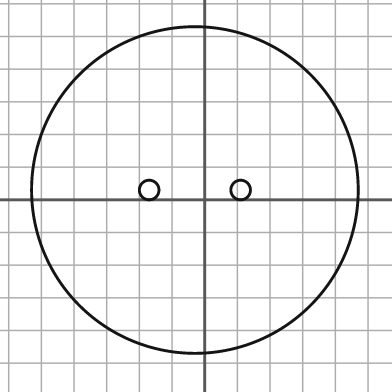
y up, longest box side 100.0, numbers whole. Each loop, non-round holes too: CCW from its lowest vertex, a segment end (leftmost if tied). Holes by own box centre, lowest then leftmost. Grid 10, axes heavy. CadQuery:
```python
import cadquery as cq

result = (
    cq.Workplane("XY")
    .moveTo(-3.0, 3.0)
    .circle(50.0)
    .moveTo(-17.0, 3.0)
    .circle(3.0)
    .moveTo(11.0, 3.0)
    .circle(3.0)
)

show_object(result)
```